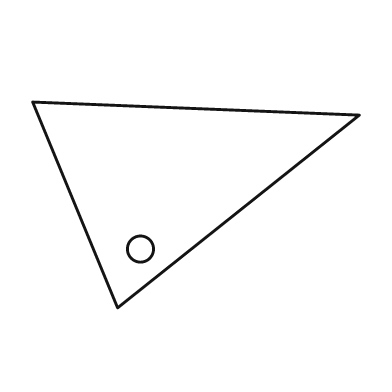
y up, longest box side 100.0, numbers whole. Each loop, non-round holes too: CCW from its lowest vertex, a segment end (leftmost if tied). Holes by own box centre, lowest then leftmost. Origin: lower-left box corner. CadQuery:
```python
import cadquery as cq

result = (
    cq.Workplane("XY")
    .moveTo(26.0, 0.0)
    .lineTo(100.0, 59.0)
    .lineTo(0.0, 63.0)
    .close()
    .moveTo(33.0, 18.0)
    .circle(4.0)
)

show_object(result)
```